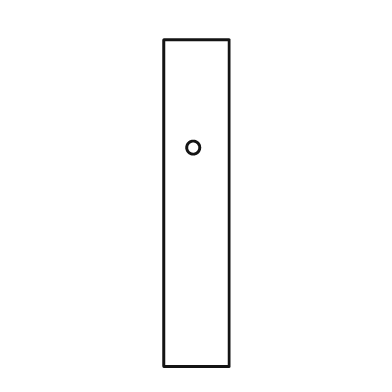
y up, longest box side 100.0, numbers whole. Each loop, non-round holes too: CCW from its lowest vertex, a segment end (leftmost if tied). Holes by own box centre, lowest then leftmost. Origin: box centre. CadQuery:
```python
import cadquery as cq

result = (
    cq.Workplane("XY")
    .moveTo(-10.0, -50.0)
    .lineTo(10.0, -50.0)
    .lineTo(10.0, 50.0)
    .lineTo(-10.0, 50.0)
    .close()
    .moveTo(-1.0, 17.0)
    .circle(2.0)
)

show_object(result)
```